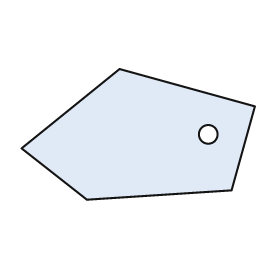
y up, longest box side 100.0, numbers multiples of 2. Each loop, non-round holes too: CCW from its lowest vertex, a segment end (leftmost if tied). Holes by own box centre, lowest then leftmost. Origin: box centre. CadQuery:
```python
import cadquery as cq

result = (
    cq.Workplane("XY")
    .moveTo(-22.0, -28.0)
    .lineTo(40.0, -24.0)
    .lineTo(50.0, 12.0)
    .lineTo(-8.0, 28.0)
    .lineTo(-50.0, -6.0)
    .close()
    .moveTo(30.0, 0.0)
    .circle(4.0)
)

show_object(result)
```